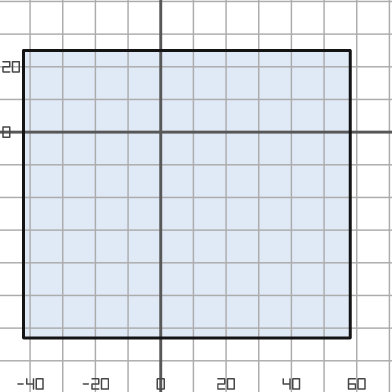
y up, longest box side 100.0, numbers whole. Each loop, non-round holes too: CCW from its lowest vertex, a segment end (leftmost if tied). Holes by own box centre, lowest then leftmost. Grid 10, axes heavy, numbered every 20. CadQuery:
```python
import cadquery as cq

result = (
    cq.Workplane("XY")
    .moveTo(-42.0, -63.0)
    .lineTo(58.0, -63.0)
    .lineTo(58.0, 25.0)
    .lineTo(-42.0, 25.0)
    .close()
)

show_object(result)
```